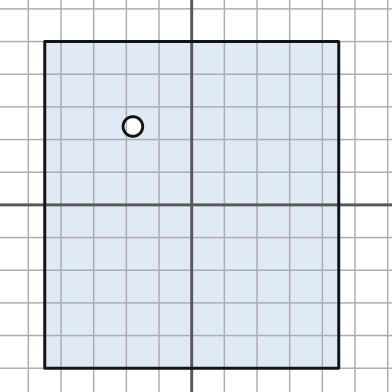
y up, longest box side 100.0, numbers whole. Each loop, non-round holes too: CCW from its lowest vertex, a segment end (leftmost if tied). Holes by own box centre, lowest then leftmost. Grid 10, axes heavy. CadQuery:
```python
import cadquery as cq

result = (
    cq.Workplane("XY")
    .moveTo(-45.0, -50.0)
    .lineTo(45.0, -50.0)
    .lineTo(45.0, 50.0)
    .lineTo(-45.0, 50.0)
    .close()
    .moveTo(-18.0, 24.0)
    .circle(3.0)
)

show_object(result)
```